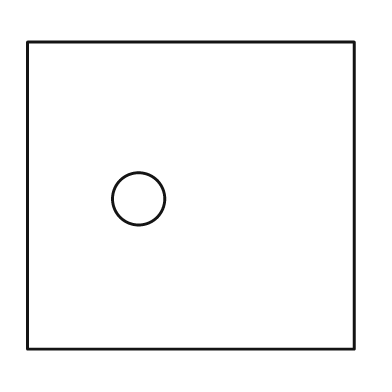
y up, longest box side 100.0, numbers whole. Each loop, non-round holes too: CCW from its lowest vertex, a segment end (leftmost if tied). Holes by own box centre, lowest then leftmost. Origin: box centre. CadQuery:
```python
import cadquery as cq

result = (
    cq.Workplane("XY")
    .moveTo(-50.0, -47.0)
    .lineTo(50.0, -47.0)
    .lineTo(50.0, 47.0)
    .lineTo(-50.0, 47.0)
    .close()
    .moveTo(-16.0, -1.0)
    .circle(8.0)
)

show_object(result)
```